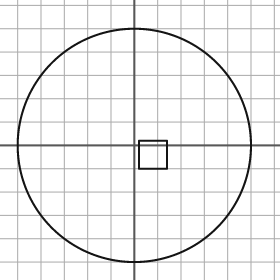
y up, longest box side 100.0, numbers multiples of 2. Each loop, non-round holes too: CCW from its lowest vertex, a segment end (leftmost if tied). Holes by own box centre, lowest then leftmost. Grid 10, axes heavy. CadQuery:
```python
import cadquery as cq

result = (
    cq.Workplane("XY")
    .moveTo(0.0, 0.0)
    .circle(50.0)
    .moveTo(2.0, -10.0)
    .lineTo(14.0, -10.0)
    .lineTo(14.0, 2.0)
    .lineTo(2.0, 2.0)
    .close()
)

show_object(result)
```